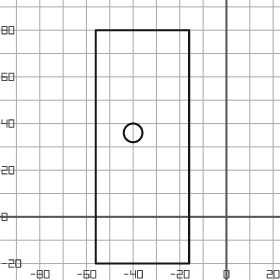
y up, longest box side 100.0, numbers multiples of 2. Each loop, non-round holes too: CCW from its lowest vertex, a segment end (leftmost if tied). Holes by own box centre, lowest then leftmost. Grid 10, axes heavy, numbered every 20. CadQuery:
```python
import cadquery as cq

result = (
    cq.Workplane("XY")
    .moveTo(-56.0, -20.0)
    .lineTo(-16.0, -20.0)
    .lineTo(-16.0, 80.0)
    .lineTo(-56.0, 80.0)
    .close()
    .moveTo(-40.0, 36.0)
    .circle(4.0)
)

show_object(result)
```